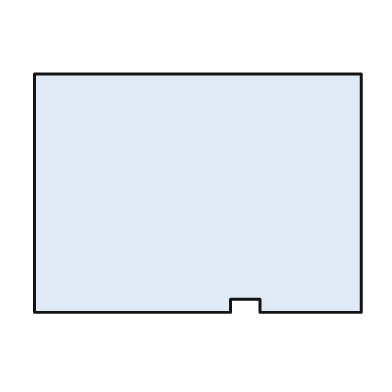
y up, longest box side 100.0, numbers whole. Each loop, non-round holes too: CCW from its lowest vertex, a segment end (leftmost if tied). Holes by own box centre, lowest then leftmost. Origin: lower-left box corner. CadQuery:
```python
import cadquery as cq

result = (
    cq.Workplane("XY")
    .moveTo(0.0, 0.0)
    .lineTo(60.0, 0.0)
    .lineTo(60.0, 4.0)
    .lineTo(69.0, 4.0)
    .lineTo(69.0, 0.0)
    .lineTo(100.0, 0.0)
    .lineTo(100.0, 73.0)
    .lineTo(0.0, 73.0)
    .close()
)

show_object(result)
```